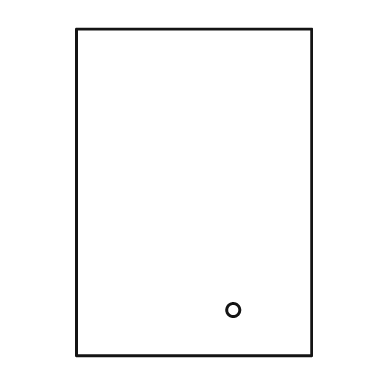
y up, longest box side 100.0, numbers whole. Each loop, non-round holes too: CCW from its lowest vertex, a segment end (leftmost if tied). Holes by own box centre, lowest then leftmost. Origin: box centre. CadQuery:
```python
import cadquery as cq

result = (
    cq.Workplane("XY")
    .moveTo(-36.0, -50.0)
    .lineTo(36.0, -50.0)
    .lineTo(36.0, 50.0)
    .lineTo(-36.0, 50.0)
    .close()
    .moveTo(12.0, -36.0)
    .circle(2.0)
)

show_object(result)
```